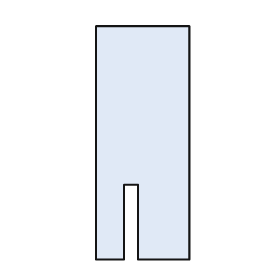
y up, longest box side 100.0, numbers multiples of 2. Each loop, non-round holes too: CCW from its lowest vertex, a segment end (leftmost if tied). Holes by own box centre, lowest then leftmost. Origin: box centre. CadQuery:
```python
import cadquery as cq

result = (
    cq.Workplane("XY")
    .moveTo(-20.0, -50.0)
    .lineTo(-8.0, -50.0)
    .lineTo(-8.0, -18.0)
    .lineTo(-2.0, -18.0)
    .lineTo(-2.0, -50.0)
    .lineTo(20.0, -50.0)
    .lineTo(20.0, 50.0)
    .lineTo(-20.0, 50.0)
    .close()
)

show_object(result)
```